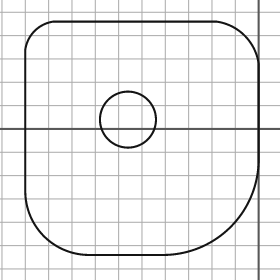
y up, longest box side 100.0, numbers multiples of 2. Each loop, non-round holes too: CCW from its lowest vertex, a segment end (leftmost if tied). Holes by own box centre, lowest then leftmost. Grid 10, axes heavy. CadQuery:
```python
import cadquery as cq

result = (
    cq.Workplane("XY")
    .moveTo(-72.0, -54.0)
    .lineTo(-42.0, -54.0)
    .threePointArc((-12.0, -42.0), (0.0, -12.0))
    .lineTo(0.0, 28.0)
    .threePointArc((-6.0, 40.0), (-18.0, 46.0))
    .lineTo(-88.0, 46.0)
    .threePointArc((-96.0, 42.0), (-100.0, 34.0))
    .lineTo(-100.0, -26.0)
    .threePointArc((-92.0, -46.0), (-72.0, -54.0))
    .close()
    .moveTo(-56.0, 4.0)
    .circle(12.0)
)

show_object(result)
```